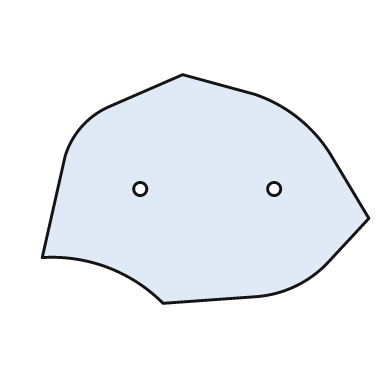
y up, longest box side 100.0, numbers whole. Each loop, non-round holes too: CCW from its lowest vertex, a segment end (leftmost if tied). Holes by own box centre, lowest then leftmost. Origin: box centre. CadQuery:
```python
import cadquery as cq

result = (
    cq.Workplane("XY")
    .moveTo(-13.0, -35.0)
    .lineTo(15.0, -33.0)
    .threePointArc((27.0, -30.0), (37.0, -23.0))
    .lineTo(50.0, -9.0)
    .lineTo(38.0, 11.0)
    .threePointArc((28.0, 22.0), (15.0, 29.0))
    .lineTo(-7.0, 35.0)
    .lineTo(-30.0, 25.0)
    .threePointArc((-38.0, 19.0), (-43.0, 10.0))
    .lineTo(-50.0, -21.0)
    .threePointArc((-30.0, -24.0), (-13.0, -35.0))
    .close()
    .moveTo(-20.0, 0.0)
    .circle(2.0)
    .moveTo(21.0, 0.0)
    .circle(2.0)
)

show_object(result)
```